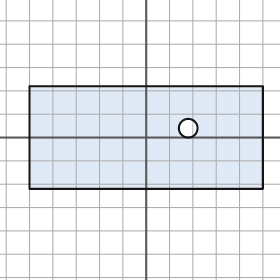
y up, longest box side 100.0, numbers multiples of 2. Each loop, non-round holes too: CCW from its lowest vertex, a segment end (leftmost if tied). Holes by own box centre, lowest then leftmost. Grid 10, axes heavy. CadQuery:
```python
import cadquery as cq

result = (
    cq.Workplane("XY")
    .moveTo(-50.0, -22.0)
    .lineTo(50.0, -22.0)
    .lineTo(50.0, 22.0)
    .lineTo(-50.0, 22.0)
    .close()
    .moveTo(18.0, 4.0)
    .circle(4.0)
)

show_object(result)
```